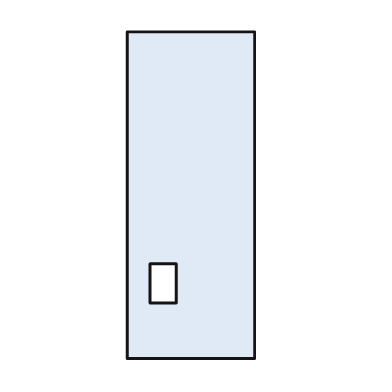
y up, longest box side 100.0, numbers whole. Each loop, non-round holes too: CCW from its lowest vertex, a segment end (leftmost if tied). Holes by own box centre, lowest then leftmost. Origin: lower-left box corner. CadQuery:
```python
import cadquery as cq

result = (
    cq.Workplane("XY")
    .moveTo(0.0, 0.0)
    .lineTo(39.0, 0.0)
    .lineTo(39.0, 100.0)
    .lineTo(0.0, 100.0)
    .close()
    .moveTo(7.0, 17.0)
    .lineTo(15.0, 17.0)
    .lineTo(15.0, 29.0)
    .lineTo(7.0, 29.0)
    .close()
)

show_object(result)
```